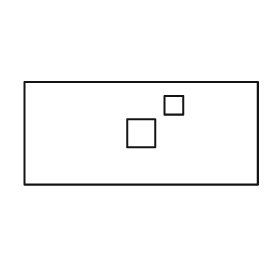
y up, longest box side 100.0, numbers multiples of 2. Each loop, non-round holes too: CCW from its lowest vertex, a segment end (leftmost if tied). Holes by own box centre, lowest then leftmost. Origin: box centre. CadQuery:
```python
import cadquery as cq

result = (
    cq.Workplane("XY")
    .moveTo(-50.0, -22.0)
    .lineTo(50.0, -22.0)
    .lineTo(50.0, 22.0)
    .lineTo(-50.0, 22.0)
    .close()
    .moveTo(-6.0, -6.0)
    .lineTo(6.0, -6.0)
    .lineTo(6.0, 6.0)
    .lineTo(-6.0, 6.0)
    .close()
    .moveTo(10.0, 8.0)
    .lineTo(18.0, 8.0)
    .lineTo(18.0, 16.0)
    .lineTo(10.0, 16.0)
    .close()
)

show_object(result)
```